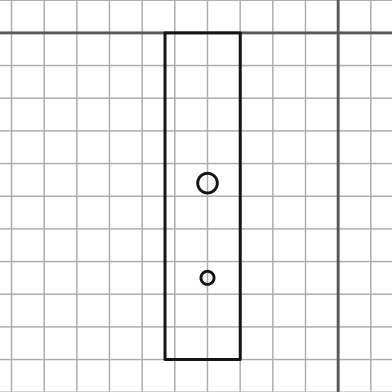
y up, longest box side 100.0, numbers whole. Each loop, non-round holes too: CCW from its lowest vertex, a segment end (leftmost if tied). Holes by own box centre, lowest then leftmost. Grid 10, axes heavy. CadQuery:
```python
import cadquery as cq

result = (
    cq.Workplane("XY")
    .moveTo(-53.0, -100.0)
    .lineTo(-30.0, -100.0)
    .lineTo(-30.0, 0.0)
    .lineTo(-53.0, 0.0)
    .close()
    .moveTo(-40.0, -75.0)
    .circle(2.0)
    .moveTo(-40.0, -46.0)
    .circle(3.0)
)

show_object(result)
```